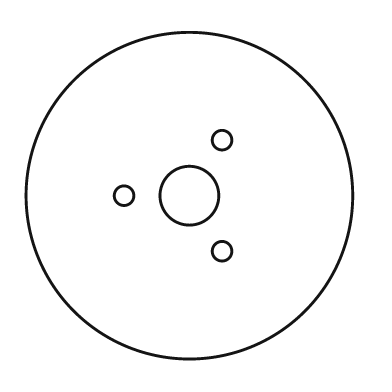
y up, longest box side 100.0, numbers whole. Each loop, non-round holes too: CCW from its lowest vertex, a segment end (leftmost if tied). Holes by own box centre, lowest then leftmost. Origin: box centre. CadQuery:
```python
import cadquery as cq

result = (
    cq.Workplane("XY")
    .moveTo(0.0, 0.0)
    .circle(50.0)
    .moveTo(10.0, -17.0)
    .circle(3.0)
    .moveTo(-20.0, 0.0)
    .circle(3.0)
    .moveTo(0.0, 0.0)
    .circle(9.0)
    .moveTo(10.0, 17.0)
    .circle(3.0)
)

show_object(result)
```